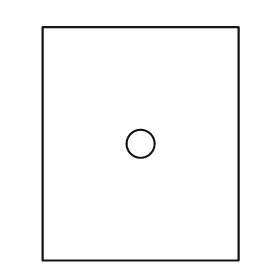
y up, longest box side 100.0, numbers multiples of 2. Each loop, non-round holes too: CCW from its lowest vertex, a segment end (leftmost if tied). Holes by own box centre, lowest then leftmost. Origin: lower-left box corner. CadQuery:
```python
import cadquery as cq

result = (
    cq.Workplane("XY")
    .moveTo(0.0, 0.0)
    .lineTo(84.0, 0.0)
    .lineTo(84.0, 100.0)
    .lineTo(0.0, 100.0)
    .close()
    .moveTo(42.0, 50.0)
    .circle(6.0)
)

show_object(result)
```